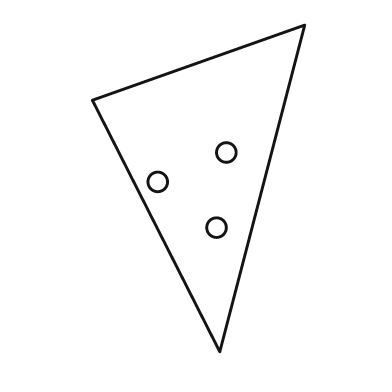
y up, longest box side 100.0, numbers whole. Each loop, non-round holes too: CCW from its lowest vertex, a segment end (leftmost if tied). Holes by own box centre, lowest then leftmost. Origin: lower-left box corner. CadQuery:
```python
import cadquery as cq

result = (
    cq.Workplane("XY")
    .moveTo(39.0, 0.0)
    .lineTo(65.0, 100.0)
    .lineTo(0.0, 77.0)
    .close()
    .moveTo(38.0, 38.0)
    .circle(3.0)
    .moveTo(20.0, 52.0)
    .circle(3.0)
    .moveTo(41.0, 61.0)
    .circle(3.0)
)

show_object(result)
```